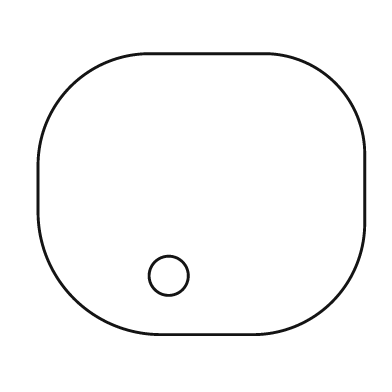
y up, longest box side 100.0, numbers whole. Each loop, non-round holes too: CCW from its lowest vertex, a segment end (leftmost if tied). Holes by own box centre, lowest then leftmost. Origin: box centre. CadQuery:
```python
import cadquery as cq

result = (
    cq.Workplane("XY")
    .moveTo(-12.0, -43.0)
    .lineTo(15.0, -43.0)
    .threePointArc((40.0, -33.0), (50.0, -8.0))
    .lineTo(50.0, 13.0)
    .threePointArc((41.0, 34.0), (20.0, 43.0))
    .lineTo(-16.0, 43.0)
    .threePointArc((-40.0, 33.0), (-50.0, 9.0))
    .lineTo(-50.0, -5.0)
    .threePointArc((-39.0, -32.0), (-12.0, -43.0))
    .close()
    .moveTo(-10.0, -25.0)
    .circle(6.0)
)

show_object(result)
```